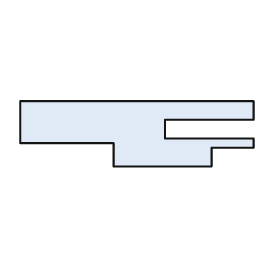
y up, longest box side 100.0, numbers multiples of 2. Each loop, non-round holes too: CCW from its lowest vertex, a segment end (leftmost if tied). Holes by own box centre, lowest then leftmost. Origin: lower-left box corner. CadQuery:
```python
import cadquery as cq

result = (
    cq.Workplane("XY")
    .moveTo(40.0, 0.0)
    .lineTo(82.0, 0.0)
    .lineTo(82.0, 8.0)
    .lineTo(100.0, 8.0)
    .lineTo(100.0, 12.0)
    .lineTo(62.0, 12.0)
    .lineTo(62.0, 20.0)
    .lineTo(100.0, 20.0)
    .lineTo(100.0, 28.0)
    .lineTo(0.0, 28.0)
    .lineTo(0.0, 10.0)
    .lineTo(40.0, 10.0)
    .close()
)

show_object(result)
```